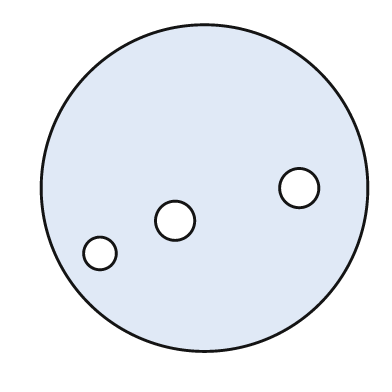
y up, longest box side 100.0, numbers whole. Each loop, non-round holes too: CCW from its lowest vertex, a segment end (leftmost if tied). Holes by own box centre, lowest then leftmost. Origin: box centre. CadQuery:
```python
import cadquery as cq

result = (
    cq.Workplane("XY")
    .moveTo(0.0, 0.0)
    .circle(50.0)
    .moveTo(-32.0, -20.0)
    .circle(5.0)
    .moveTo(-9.0, -10.0)
    .circle(6.0)
    .moveTo(29.0, 0.0)
    .circle(6.0)
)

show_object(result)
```